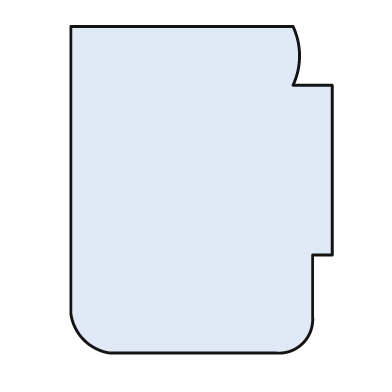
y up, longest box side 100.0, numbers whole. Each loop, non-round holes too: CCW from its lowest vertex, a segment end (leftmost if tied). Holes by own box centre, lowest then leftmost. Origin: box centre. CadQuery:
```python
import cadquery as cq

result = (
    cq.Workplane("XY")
    .moveTo(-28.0, -50.0)
    .lineTo(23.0, -50.0)
    .threePointArc((31.0, -47.0), (34.0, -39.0))
    .lineTo(34.0, -20.0)
    .lineTo(40.0, -20.0)
    .lineTo(40.0, 32.0)
    .lineTo(28.0, 32.0)
    .threePointArc((30.0, 41.0), (28.0, 50.0))
    .lineTo(-40.0, 50.0)
    .lineTo(-40.0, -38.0)
    .threePointArc((-36.0, -46.0), (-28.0, -50.0))
    .close()
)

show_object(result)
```